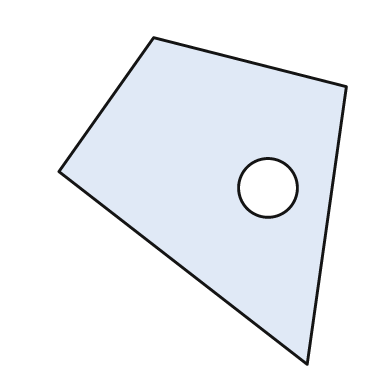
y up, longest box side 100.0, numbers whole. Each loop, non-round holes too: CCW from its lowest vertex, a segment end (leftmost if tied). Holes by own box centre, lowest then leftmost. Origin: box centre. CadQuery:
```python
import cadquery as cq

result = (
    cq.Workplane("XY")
    .moveTo(32.0, -50.0)
    .lineTo(44.0, 35.0)
    .lineTo(-15.0, 50.0)
    .lineTo(-44.0, 9.0)
    .close()
    .moveTo(20.0, 4.0)
    .circle(9.0)
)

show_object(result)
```